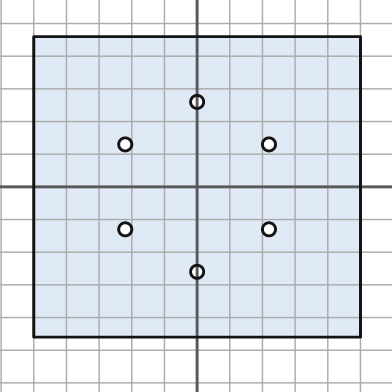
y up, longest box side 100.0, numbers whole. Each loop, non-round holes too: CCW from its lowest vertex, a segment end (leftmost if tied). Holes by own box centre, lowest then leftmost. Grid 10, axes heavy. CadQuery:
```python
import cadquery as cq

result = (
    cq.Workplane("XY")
    .moveTo(-50.0, -46.0)
    .lineTo(50.0, -46.0)
    .lineTo(50.0, 46.0)
    .lineTo(-50.0, 46.0)
    .close()
    .moveTo(0.0, -26.0)
    .circle(2.0)
    .moveTo(-22.0, -13.0)
    .circle(2.0)
    .moveTo(22.0, -13.0)
    .circle(2.0)
    .moveTo(-22.0, 13.0)
    .circle(2.0)
    .moveTo(22.0, 13.0)
    .circle(2.0)
    .moveTo(0.0, 26.0)
    .circle(2.0)
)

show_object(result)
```